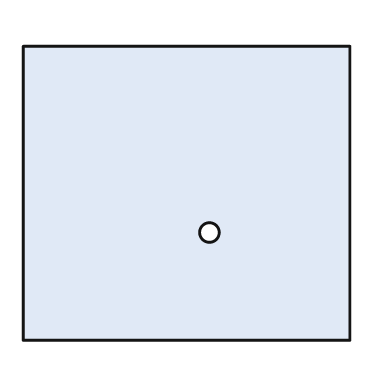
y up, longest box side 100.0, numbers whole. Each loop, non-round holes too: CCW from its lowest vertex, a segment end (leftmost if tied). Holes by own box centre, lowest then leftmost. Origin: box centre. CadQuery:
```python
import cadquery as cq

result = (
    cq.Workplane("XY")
    .moveTo(-50.0, -45.0)
    .lineTo(50.0, -45.0)
    .lineTo(50.0, 45.0)
    .lineTo(-50.0, 45.0)
    .close()
    .moveTo(7.0, -12.0)
    .circle(3.0)
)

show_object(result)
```